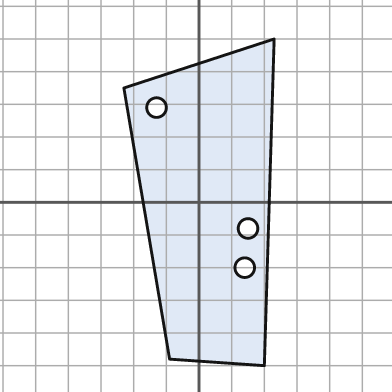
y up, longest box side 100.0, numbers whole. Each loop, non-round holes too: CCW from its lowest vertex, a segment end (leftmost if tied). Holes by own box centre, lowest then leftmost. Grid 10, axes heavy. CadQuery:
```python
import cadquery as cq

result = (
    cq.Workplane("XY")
    .moveTo(20.0, -50.0)
    .lineTo(23.0, 50.0)
    .lineTo(-23.0, 35.0)
    .lineTo(-9.0, -48.0)
    .close()
    .moveTo(14.0, -20.0)
    .circle(3.0)
    .moveTo(15.0, -8.0)
    .circle(3.0)
    .moveTo(-13.0, 29.0)
    .circle(3.0)
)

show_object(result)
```